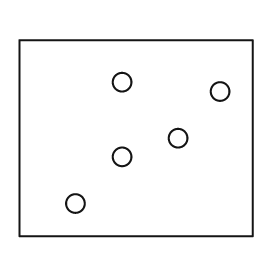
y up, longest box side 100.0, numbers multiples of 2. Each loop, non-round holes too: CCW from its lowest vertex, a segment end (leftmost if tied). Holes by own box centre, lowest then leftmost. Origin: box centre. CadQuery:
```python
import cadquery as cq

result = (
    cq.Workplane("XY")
    .moveTo(-50.0, -42.0)
    .lineTo(50.0, -42.0)
    .lineTo(50.0, 42.0)
    .lineTo(-50.0, 42.0)
    .close()
    .moveTo(-26.0, -28.0)
    .circle(4.0)
    .moveTo(-6.0, -8.0)
    .circle(4.0)
    .moveTo(18.0, 0.0)
    .circle(4.0)
    .moveTo(36.0, 20.0)
    .circle(4.0)
    .moveTo(-6.0, 24.0)
    .circle(4.0)
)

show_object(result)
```